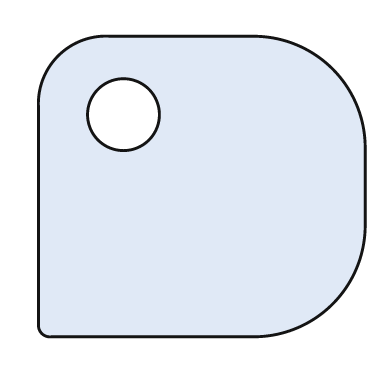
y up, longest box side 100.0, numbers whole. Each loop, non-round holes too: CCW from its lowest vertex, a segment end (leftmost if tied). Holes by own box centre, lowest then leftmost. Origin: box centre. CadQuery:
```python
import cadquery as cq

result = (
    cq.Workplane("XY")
    .moveTo(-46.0, -46.0)
    .lineTo(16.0, -46.0)
    .threePointArc((40.0, -36.0), (50.0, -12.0))
    .lineTo(50.0, 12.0)
    .threePointArc((40.0, 36.0), (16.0, 46.0))
    .lineTo(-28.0, 46.0)
    .threePointArc((-44.0, 40.0), (-50.0, 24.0))
    .lineTo(-50.0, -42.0)
    .threePointArc((-49.0, -45.0), (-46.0, -46.0))
    .close()
    .moveTo(-24.0, 22.0)
    .circle(11.0)
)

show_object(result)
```